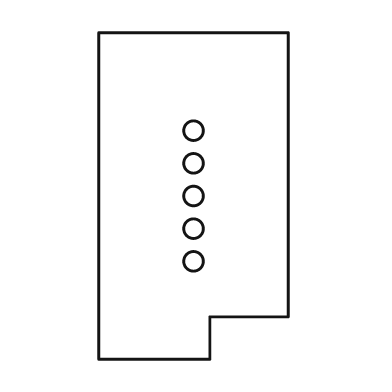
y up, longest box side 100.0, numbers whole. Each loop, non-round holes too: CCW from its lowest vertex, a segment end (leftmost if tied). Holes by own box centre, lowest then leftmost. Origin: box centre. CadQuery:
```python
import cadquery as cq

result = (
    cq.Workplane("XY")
    .moveTo(-29.0, -50.0)
    .lineTo(5.0, -50.0)
    .lineTo(5.0, -37.0)
    .lineTo(29.0, -37.0)
    .lineTo(29.0, 50.0)
    .lineTo(-29.0, 50.0)
    .close()
    .moveTo(0.0, -20.0)
    .circle(3.0)
    .moveTo(0.0, -10.0)
    .circle(3.0)
    .moveTo(0.0, 0.0)
    .circle(3.0)
    .moveTo(0.0, 10.0)
    .circle(3.0)
    .moveTo(0.0, 20.0)
    .circle(3.0)
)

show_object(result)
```